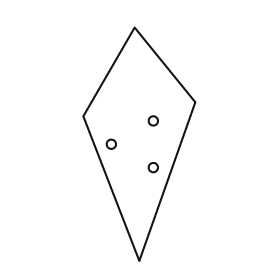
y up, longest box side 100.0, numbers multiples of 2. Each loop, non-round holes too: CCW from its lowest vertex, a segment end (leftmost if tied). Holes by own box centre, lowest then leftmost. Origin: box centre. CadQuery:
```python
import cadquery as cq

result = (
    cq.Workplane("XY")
    .moveTo(0.0, -50.0)
    .lineTo(24.0, 18.0)
    .lineTo(-2.0, 50.0)
    .lineTo(-24.0, 12.0)
    .close()
    .moveTo(6.0, -10.0)
    .circle(2.0)
    .moveTo(-12.0, 0.0)
    .circle(2.0)
    .moveTo(6.0, 10.0)
    .circle(2.0)
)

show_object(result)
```